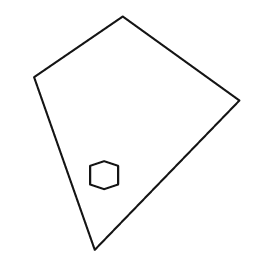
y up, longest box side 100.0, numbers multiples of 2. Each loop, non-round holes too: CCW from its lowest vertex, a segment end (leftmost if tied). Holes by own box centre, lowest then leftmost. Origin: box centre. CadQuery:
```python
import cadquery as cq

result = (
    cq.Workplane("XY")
    .moveTo(-18.0, -50.0)
    .lineTo(44.0, 14.0)
    .lineTo(-6.0, 50.0)
    .lineTo(-44.0, 24.0)
    .close()
    .moveTo(-14.0, -24.0)
    .lineTo(-8.0, -22.0)
    .lineTo(-8.0, -14.0)
    .lineTo(-14.0, -12.0)
    .lineTo(-20.0, -14.0)
    .lineTo(-20.0, -22.0)
    .close()
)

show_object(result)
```